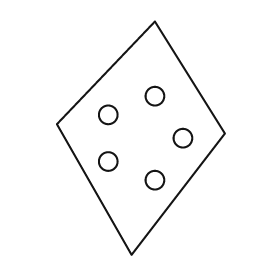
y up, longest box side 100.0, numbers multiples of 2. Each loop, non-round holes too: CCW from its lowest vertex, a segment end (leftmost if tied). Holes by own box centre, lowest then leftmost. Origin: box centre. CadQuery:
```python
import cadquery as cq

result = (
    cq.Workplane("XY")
    .moveTo(-4.0, -50.0)
    .lineTo(36.0, 2.0)
    .lineTo(6.0, 50.0)
    .lineTo(-36.0, 6.0)
    .close()
    .moveTo(6.0, -18.0)
    .circle(4.0)
    .moveTo(-14.0, -10.0)
    .circle(4.0)
    .moveTo(18.0, 0.0)
    .circle(4.0)
    .moveTo(-14.0, 10.0)
    .circle(4.0)
    .moveTo(6.0, 18.0)
    .circle(4.0)
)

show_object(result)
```